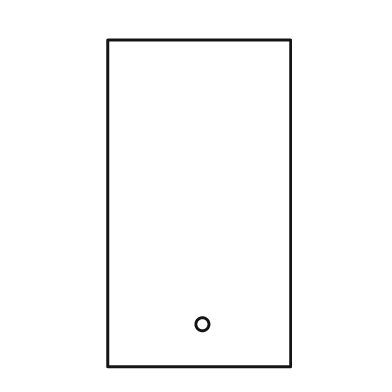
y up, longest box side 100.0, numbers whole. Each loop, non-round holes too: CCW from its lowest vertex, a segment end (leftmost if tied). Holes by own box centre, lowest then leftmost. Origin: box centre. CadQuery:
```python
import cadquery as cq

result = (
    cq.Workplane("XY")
    .moveTo(-28.0, -50.0)
    .lineTo(28.0, -50.0)
    .lineTo(28.0, 50.0)
    .lineTo(-28.0, 50.0)
    .close()
    .moveTo(1.0, -37.0)
    .circle(2.0)
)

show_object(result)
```